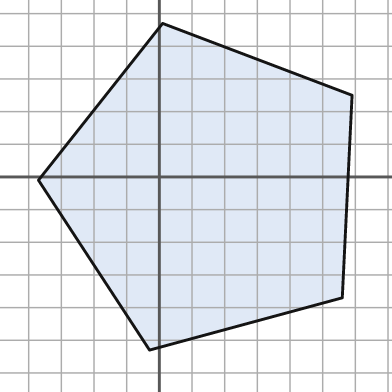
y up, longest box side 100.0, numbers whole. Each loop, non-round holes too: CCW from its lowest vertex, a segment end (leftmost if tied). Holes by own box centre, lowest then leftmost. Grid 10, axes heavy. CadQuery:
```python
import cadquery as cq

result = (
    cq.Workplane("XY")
    .moveTo(-3.0, -53.0)
    .lineTo(56.0, -37.0)
    .lineTo(59.0, 25.0)
    .lineTo(1.0, 47.0)
    .lineTo(-37.0, -1.0)
    .close()
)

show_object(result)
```